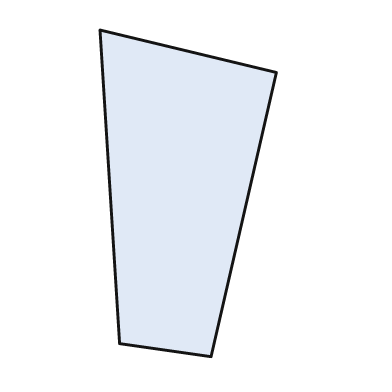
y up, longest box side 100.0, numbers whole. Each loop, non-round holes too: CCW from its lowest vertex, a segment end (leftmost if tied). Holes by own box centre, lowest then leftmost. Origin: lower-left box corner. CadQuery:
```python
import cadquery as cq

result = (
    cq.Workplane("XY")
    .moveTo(34.0, 0.0)
    .lineTo(54.0, 87.0)
    .lineTo(0.0, 100.0)
    .lineTo(6.0, 4.0)
    .close()
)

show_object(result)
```